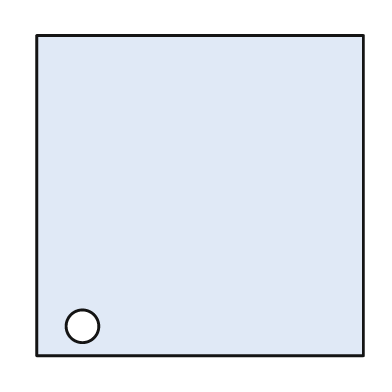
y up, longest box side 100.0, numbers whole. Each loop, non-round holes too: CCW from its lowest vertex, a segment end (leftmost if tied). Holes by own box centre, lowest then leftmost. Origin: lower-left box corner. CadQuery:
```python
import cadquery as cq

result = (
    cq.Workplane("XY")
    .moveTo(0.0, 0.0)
    .lineTo(100.0, 0.0)
    .lineTo(100.0, 98.0)
    .lineTo(0.0, 98.0)
    .close()
    .moveTo(14.0, 9.0)
    .circle(5.0)
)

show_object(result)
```